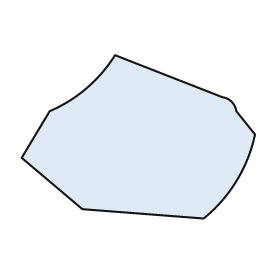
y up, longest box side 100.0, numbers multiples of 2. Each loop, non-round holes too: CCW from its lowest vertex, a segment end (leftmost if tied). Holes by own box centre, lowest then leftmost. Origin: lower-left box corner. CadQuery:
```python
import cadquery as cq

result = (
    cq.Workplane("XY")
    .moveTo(78.0, 0.0)
    .threePointArc((92.0, 16.0), (100.0, 36.0))
    .lineTo(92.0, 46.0)
    .threePointArc((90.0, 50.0), (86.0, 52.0))
    .lineTo(40.0, 70.0)
    .threePointArc((28.0, 56.0), (12.0, 46.0))
    .lineTo(0.0, 26.0)
    .lineTo(26.0, 4.0)
    .close()
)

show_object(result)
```